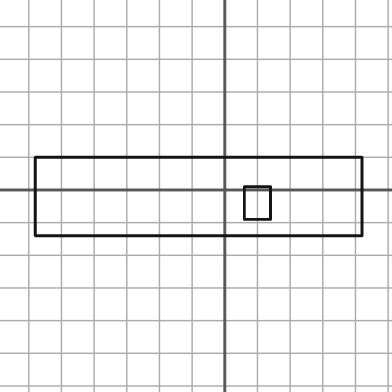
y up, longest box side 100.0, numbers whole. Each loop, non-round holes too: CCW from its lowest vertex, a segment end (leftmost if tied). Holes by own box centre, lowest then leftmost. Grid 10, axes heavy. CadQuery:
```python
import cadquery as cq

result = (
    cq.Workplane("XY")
    .moveTo(-58.0, -14.0)
    .lineTo(42.0, -14.0)
    .lineTo(42.0, 10.0)
    .lineTo(-58.0, 10.0)
    .close()
    .moveTo(6.0, -9.0)
    .lineTo(14.0, -9.0)
    .lineTo(14.0, 1.0)
    .lineTo(6.0, 1.0)
    .close()
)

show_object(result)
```